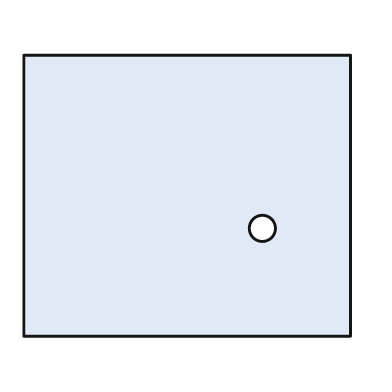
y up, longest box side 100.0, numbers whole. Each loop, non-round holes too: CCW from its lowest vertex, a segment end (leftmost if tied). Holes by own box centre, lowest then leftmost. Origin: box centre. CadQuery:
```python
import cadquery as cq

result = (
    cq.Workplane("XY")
    .moveTo(-50.0, -43.0)
    .lineTo(50.0, -43.0)
    .lineTo(50.0, 43.0)
    .lineTo(-50.0, 43.0)
    .close()
    .moveTo(23.0, -10.0)
    .circle(4.0)
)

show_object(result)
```